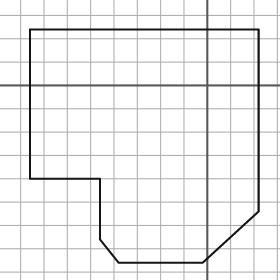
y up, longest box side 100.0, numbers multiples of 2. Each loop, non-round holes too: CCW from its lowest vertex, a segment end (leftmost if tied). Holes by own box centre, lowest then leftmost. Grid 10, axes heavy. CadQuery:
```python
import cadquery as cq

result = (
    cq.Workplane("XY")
    .moveTo(-38.0, -76.0)
    .lineTo(-2.0, -76.0)
    .lineTo(22.0, -54.0)
    .lineTo(22.0, 24.0)
    .lineTo(-76.0, 24.0)
    .lineTo(-76.0, -40.0)
    .lineTo(-46.0, -40.0)
    .lineTo(-46.0, -66.0)
    .close()
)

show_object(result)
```